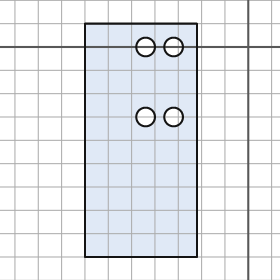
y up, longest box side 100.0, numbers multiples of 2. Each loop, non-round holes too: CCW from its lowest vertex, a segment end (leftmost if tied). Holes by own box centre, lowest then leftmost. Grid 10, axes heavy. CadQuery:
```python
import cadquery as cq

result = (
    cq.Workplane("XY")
    .moveTo(-70.0, -90.0)
    .lineTo(-22.0, -90.0)
    .lineTo(-22.0, 10.0)
    .lineTo(-70.0, 10.0)
    .close()
    .moveTo(-44.0, -30.0)
    .circle(4.0)
    .moveTo(-32.0, -30.0)
    .circle(4.0)
    .moveTo(-44.0, 0.0)
    .circle(4.0)
    .moveTo(-32.0, 0.0)
    .circle(4.0)
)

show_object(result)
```